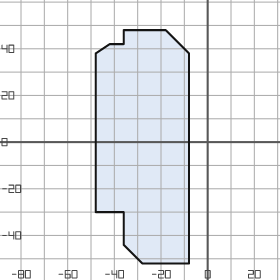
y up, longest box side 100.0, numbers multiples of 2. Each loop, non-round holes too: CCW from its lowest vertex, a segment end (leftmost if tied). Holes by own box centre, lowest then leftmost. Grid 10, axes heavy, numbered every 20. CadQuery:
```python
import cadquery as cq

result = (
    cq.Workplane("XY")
    .moveTo(-28.0, -52.0)
    .lineTo(-8.0, -52.0)
    .lineTo(-8.0, 38.0)
    .lineTo(-18.0, 48.0)
    .lineTo(-36.0, 48.0)
    .lineTo(-36.0, 42.0)
    .lineTo(-42.0, 42.0)
    .lineTo(-48.0, 38.0)
    .lineTo(-48.0, -30.0)
    .lineTo(-36.0, -30.0)
    .lineTo(-36.0, -44.0)
    .close()
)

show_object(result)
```